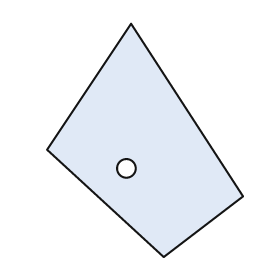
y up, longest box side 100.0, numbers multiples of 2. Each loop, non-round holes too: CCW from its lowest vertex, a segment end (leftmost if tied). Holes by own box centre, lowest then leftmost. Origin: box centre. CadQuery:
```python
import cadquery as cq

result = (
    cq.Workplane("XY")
    .moveTo(8.0, -50.0)
    .lineTo(42.0, -24.0)
    .lineTo(-6.0, 50.0)
    .lineTo(-42.0, -4.0)
    .close()
    .moveTo(-8.0, -12.0)
    .circle(4.0)
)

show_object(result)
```